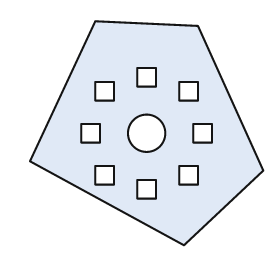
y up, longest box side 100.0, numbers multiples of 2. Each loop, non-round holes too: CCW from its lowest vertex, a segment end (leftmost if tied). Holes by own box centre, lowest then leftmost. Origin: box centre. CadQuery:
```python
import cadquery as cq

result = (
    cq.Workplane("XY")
    .moveTo(16.0, -48.0)
    .lineTo(50.0, -16.0)
    .lineTo(22.0, 46.0)
    .lineTo(-22.0, 48.0)
    .lineTo(-50.0, -12.0)
    .close()
    .moveTo(-4.0, -28.0)
    .lineTo(4.0, -28.0)
    .lineTo(4.0, -20.0)
    .lineTo(-4.0, -20.0)
    .close()
    .moveTo(-22.0, -22.0)
    .lineTo(-14.0, -22.0)
    .lineTo(-14.0, -14.0)
    .lineTo(-22.0, -14.0)
    .close()
    .moveTo(14.0, -22.0)
    .lineTo(22.0, -22.0)
    .lineTo(22.0, -14.0)
    .lineTo(14.0, -14.0)
    .close()
    .moveTo(-28.0, -4.0)
    .lineTo(-20.0, -4.0)
    .lineTo(-20.0, 4.0)
    .lineTo(-28.0, 4.0)
    .close()
    .moveTo(0.0, 0.0)
    .circle(8.0)
    .moveTo(20.0, -4.0)
    .lineTo(28.0, -4.0)
    .lineTo(28.0, 4.0)
    .lineTo(20.0, 4.0)
    .close()
    .moveTo(-22.0, 14.0)
    .lineTo(-14.0, 14.0)
    .lineTo(-14.0, 22.0)
    .lineTo(-22.0, 22.0)
    .close()
    .moveTo(14.0, 14.0)
    .lineTo(22.0, 14.0)
    .lineTo(22.0, 22.0)
    .lineTo(14.0, 22.0)
    .close()
    .moveTo(-4.0, 20.0)
    .lineTo(4.0, 20.0)
    .lineTo(4.0, 28.0)
    .lineTo(-4.0, 28.0)
    .close()
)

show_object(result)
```